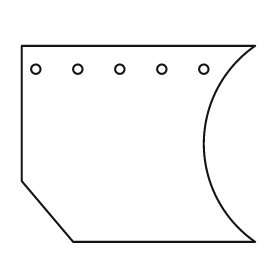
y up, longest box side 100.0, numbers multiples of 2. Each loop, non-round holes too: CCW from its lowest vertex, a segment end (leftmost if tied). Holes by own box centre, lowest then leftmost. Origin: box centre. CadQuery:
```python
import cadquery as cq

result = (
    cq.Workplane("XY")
    .moveTo(-28.0, -42.0)
    .lineTo(50.0, -42.0)
    .threePointArc((28.0, 0.0), (50.0, 42.0))
    .lineTo(-50.0, 42.0)
    .lineTo(-50.0, -16.0)
    .close()
    .moveTo(-44.0, 32.0)
    .circle(2.0)
    .moveTo(-26.0, 32.0)
    .circle(2.0)
    .moveTo(-8.0, 32.0)
    .circle(2.0)
    .moveTo(10.0, 32.0)
    .circle(2.0)
    .moveTo(28.0, 32.0)
    .circle(2.0)
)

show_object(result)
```